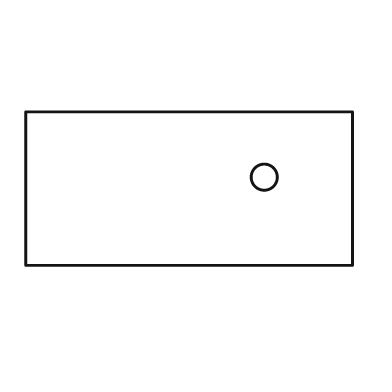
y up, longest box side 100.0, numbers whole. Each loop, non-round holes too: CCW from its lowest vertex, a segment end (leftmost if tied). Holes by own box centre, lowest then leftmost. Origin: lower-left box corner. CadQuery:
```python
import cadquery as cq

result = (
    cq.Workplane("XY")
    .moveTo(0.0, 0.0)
    .lineTo(100.0, 0.0)
    .lineTo(100.0, 47.0)
    .lineTo(0.0, 47.0)
    .close()
    .moveTo(73.0, 27.0)
    .circle(4.0)
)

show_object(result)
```